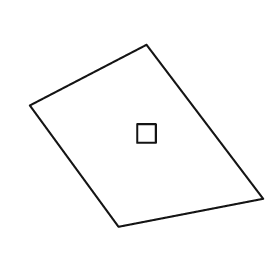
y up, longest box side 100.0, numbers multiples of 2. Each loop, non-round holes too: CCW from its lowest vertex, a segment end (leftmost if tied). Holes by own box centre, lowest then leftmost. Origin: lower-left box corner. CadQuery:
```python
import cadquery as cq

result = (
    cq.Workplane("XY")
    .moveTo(38.0, 0.0)
    .lineTo(100.0, 12.0)
    .lineTo(50.0, 78.0)
    .lineTo(0.0, 52.0)
    .close()
    .moveTo(46.0, 36.0)
    .lineTo(54.0, 36.0)
    .lineTo(54.0, 44.0)
    .lineTo(46.0, 44.0)
    .close()
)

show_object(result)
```